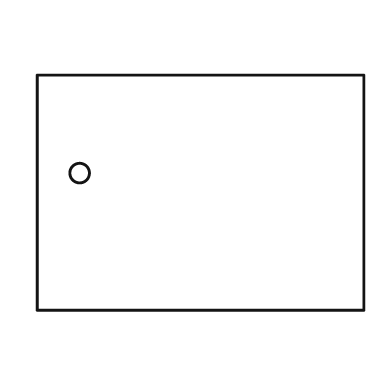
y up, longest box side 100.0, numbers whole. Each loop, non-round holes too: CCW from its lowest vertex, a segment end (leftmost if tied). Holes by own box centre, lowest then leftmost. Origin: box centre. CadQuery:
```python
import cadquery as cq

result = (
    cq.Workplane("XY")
    .moveTo(-50.0, -36.0)
    .lineTo(50.0, -36.0)
    .lineTo(50.0, 36.0)
    .lineTo(-50.0, 36.0)
    .close()
    .moveTo(-37.0, 6.0)
    .circle(3.0)
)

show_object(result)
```